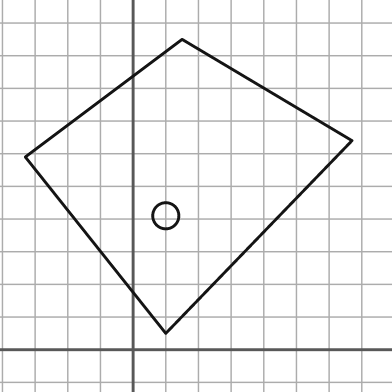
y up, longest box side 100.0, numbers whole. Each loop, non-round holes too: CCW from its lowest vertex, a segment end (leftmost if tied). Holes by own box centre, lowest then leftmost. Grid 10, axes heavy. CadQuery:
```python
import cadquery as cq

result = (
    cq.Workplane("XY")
    .moveTo(10.0, 5.0)
    .lineTo(67.0, 64.0)
    .lineTo(15.0, 95.0)
    .lineTo(-33.0, 59.0)
    .close()
    .moveTo(10.0, 41.0)
    .circle(4.0)
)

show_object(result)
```